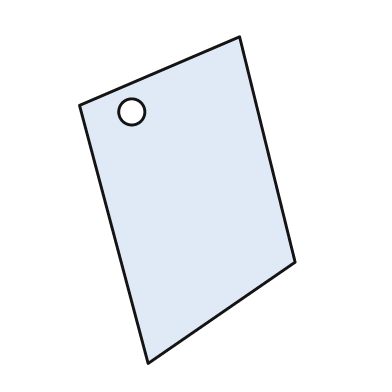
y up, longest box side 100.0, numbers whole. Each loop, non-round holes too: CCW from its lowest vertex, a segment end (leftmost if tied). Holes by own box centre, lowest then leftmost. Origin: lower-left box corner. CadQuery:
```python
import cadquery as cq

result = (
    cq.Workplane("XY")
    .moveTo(21.0, 0.0)
    .lineTo(66.0, 31.0)
    .lineTo(49.0, 100.0)
    .lineTo(0.0, 79.0)
    .close()
    .moveTo(16.0, 77.0)
    .circle(4.0)
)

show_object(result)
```